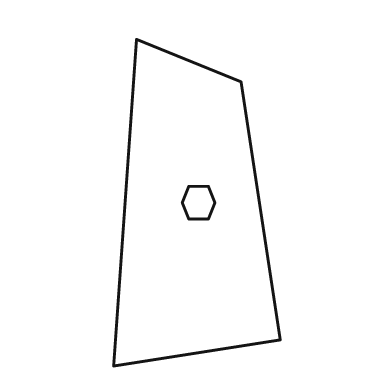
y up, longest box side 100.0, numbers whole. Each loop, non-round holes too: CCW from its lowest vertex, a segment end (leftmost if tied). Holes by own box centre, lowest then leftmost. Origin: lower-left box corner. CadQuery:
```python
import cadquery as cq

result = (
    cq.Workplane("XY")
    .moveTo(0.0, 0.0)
    .lineTo(51.0, 8.0)
    .lineTo(39.0, 87.0)
    .lineTo(7.0, 100.0)
    .close()
    .moveTo(23.0, 45.0)
    .lineTo(29.0, 45.0)
    .lineTo(31.0, 50.0)
    .lineTo(29.0, 55.0)
    .lineTo(23.0, 55.0)
    .lineTo(21.0, 50.0)
    .close()
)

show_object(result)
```